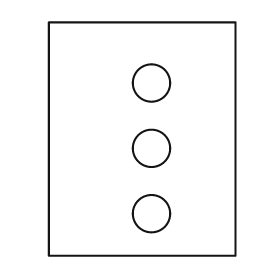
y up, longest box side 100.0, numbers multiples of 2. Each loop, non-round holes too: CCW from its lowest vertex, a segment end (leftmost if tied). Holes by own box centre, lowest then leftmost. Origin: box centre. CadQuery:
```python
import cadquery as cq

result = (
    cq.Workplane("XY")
    .moveTo(-40.0, -50.0)
    .lineTo(40.0, -50.0)
    .lineTo(40.0, 50.0)
    .lineTo(-40.0, 50.0)
    .close()
    .moveTo(4.0, -32.0)
    .circle(8.0)
    .moveTo(4.0, -4.0)
    .circle(8.0)
    .moveTo(4.0, 24.0)
    .circle(8.0)
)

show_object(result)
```